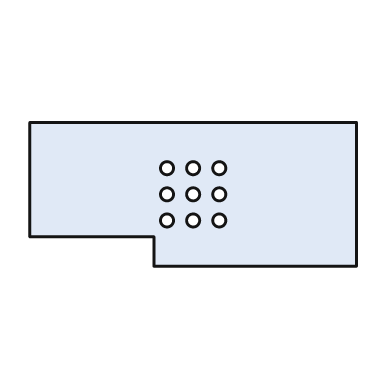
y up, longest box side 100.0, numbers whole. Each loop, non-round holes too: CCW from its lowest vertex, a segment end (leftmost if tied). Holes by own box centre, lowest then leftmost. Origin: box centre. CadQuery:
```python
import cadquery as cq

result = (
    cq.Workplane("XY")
    .moveTo(-12.0, -22.0)
    .lineTo(50.0, -22.0)
    .lineTo(50.0, 22.0)
    .lineTo(-50.0, 22.0)
    .lineTo(-50.0, -13.0)
    .lineTo(-12.0, -13.0)
    .close()
    .moveTo(-8.0, -8.0)
    .circle(2.0)
    .moveTo(0.0, -8.0)
    .circle(2.0)
    .moveTo(8.0, -8.0)
    .circle(2.0)
    .moveTo(-8.0, 0.0)
    .circle(2.0)
    .moveTo(0.0, 0.0)
    .circle(2.0)
    .moveTo(8.0, 0.0)
    .circle(2.0)
    .moveTo(-8.0, 8.0)
    .circle(2.0)
    .moveTo(0.0, 8.0)
    .circle(2.0)
    .moveTo(8.0, 8.0)
    .circle(2.0)
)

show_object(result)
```